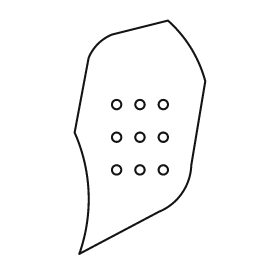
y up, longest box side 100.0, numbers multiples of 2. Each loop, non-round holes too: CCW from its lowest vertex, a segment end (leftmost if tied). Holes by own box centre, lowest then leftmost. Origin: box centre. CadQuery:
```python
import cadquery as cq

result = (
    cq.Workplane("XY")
    .moveTo(-26.0, -50.0)
    .lineTo(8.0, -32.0)
    .threePointArc((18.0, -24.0), (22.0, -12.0))
    .lineTo(28.0, 24.0)
    .threePointArc((22.0, 38.0), (12.0, 50.0))
    .lineTo(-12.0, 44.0)
    .threePointArc((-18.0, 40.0), (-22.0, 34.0))
    .lineTo(-28.0, 2.0)
    .threePointArc((-22.0, -24.0), (-26.0, -50.0))
    .close()
    .moveTo(-10.0, -14.0)
    .circle(2.0)
    .moveTo(0.0, -14.0)
    .circle(2.0)
    .moveTo(10.0, -14.0)
    .circle(2.0)
    .moveTo(-10.0, 0.0)
    .circle(2.0)
    .moveTo(0.0, 0.0)
    .circle(2.0)
    .moveTo(10.0, 0.0)
    .circle(2.0)
    .moveTo(-10.0, 14.0)
    .circle(2.0)
    .moveTo(0.0, 14.0)
    .circle(2.0)
    .moveTo(10.0, 14.0)
    .circle(2.0)
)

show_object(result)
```